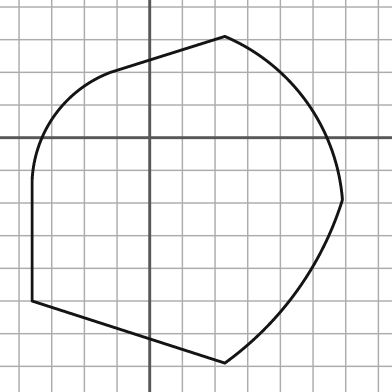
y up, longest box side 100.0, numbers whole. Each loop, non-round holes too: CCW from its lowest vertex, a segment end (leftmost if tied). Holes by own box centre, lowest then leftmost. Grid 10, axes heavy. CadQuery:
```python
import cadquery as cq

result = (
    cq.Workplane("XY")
    .moveTo(23.0, -69.0)
    .threePointArc((45.0, -47.0), (59.0, -19.0))
    .threePointArc((48.0, 11.0), (23.0, 31.0))
    .lineTo(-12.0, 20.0)
    .threePointArc((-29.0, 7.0), (-36.0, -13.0))
    .lineTo(-36.0, -50.0)
    .close()
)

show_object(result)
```